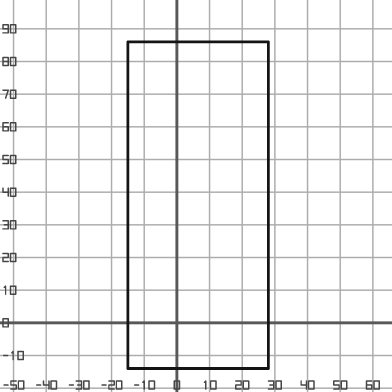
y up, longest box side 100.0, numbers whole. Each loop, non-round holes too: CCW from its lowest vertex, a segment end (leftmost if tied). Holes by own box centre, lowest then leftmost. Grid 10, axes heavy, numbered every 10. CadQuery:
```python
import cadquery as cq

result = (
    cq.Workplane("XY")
    .moveTo(-15.0, -14.0)
    .lineTo(28.0, -14.0)
    .lineTo(28.0, 86.0)
    .lineTo(-15.0, 86.0)
    .close()
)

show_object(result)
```